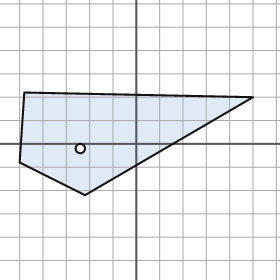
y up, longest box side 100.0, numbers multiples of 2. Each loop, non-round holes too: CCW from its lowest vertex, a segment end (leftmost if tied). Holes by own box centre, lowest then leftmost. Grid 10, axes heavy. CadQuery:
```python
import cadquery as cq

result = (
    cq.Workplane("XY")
    .moveTo(-22.0, -22.0)
    .lineTo(50.0, 20.0)
    .lineTo(-48.0, 22.0)
    .lineTo(-50.0, -8.0)
    .close()
    .moveTo(-24.0, -2.0)
    .circle(2.0)
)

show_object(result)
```